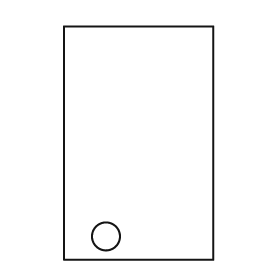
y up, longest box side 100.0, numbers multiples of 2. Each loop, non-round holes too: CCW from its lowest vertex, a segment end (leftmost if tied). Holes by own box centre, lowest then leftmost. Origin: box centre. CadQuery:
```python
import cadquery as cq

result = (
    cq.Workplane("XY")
    .moveTo(-32.0, -50.0)
    .lineTo(32.0, -50.0)
    .lineTo(32.0, 50.0)
    .lineTo(-32.0, 50.0)
    .close()
    .moveTo(-14.0, -40.0)
    .circle(6.0)
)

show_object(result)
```